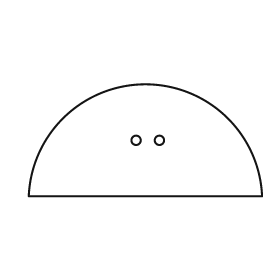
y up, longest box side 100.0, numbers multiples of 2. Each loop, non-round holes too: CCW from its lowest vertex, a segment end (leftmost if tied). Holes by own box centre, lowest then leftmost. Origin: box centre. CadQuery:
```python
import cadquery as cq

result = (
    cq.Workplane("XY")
    .moveTo(-50.0, -24.0)
    .lineTo(50.0, -24.0)
    .threePointArc((0.0, 24.0), (-50.0, -24.0))
    .close()
    .moveTo(-4.0, 0.0)
    .circle(2.0)
    .moveTo(6.0, 0.0)
    .circle(2.0)
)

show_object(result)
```